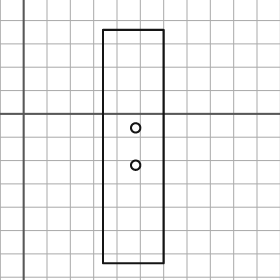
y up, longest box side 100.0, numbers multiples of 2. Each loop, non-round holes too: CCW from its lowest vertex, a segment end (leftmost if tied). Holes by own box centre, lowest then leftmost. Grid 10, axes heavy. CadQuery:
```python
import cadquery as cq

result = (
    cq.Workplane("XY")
    .moveTo(34.0, -64.0)
    .lineTo(60.0, -64.0)
    .lineTo(60.0, 36.0)
    .lineTo(34.0, 36.0)
    .close()
    .moveTo(48.0, -22.0)
    .circle(2.0)
    .moveTo(48.0, -6.0)
    .circle(2.0)
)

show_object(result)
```